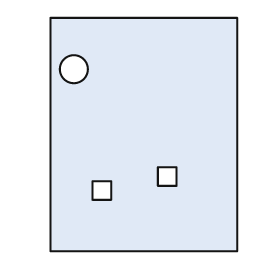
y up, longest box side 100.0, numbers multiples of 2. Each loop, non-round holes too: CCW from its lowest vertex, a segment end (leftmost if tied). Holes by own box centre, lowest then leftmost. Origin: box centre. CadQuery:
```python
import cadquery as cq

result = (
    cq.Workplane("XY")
    .moveTo(-40.0, -50.0)
    .lineTo(40.0, -50.0)
    .lineTo(40.0, 50.0)
    .lineTo(-40.0, 50.0)
    .close()
    .moveTo(-22.0, -28.0)
    .lineTo(-14.0, -28.0)
    .lineTo(-14.0, -20.0)
    .lineTo(-22.0, -20.0)
    .close()
    .moveTo(6.0, -22.0)
    .lineTo(14.0, -22.0)
    .lineTo(14.0, -14.0)
    .lineTo(6.0, -14.0)
    .close()
    .moveTo(-30.0, 28.0)
    .circle(6.0)
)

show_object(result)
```